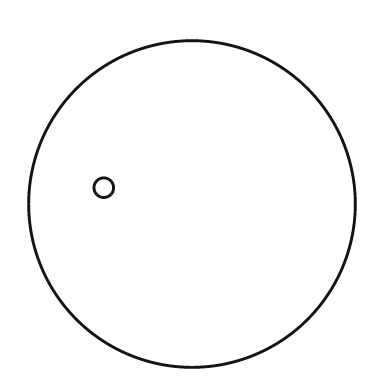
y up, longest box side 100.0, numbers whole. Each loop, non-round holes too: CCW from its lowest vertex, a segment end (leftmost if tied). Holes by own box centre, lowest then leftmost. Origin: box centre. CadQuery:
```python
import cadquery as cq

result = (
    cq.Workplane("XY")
    .moveTo(0.0, 0.0)
    .circle(50.0)
    .moveTo(-27.0, 5.0)
    .circle(3.0)
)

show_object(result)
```